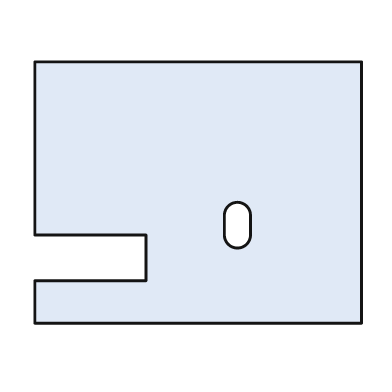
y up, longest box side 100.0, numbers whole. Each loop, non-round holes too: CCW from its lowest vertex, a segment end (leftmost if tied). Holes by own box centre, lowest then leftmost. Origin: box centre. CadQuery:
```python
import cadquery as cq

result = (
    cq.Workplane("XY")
    .moveTo(-50.0, -40.0)
    .lineTo(50.0, -40.0)
    .lineTo(50.0, 40.0)
    .lineTo(-50.0, 40.0)
    .lineTo(-50.0, -13.0)
    .lineTo(-16.0, -13.0)
    .lineTo(-16.0, -27.0)
    .lineTo(-50.0, -27.0)
    .close()
    .moveTo(8.0, -13.0)
    .threePointArc((12.0, -17.0), (16.0, -13.0))
    .lineTo(16.0, -7.0)
    .threePointArc((12.0, -3.0), (8.0, -7.0))
    .close()
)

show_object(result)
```